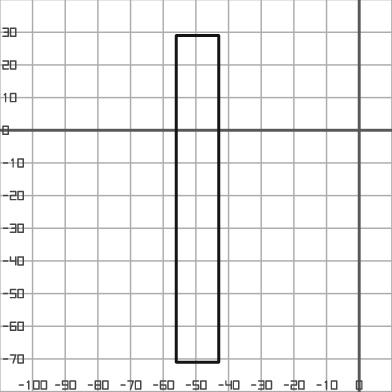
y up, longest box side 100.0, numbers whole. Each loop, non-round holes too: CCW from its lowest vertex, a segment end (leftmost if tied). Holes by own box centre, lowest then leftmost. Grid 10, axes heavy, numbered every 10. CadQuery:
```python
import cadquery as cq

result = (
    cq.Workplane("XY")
    .moveTo(-56.0, -71.0)
    .lineTo(-43.0, -71.0)
    .lineTo(-43.0, 29.0)
    .lineTo(-56.0, 29.0)
    .close()
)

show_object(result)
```